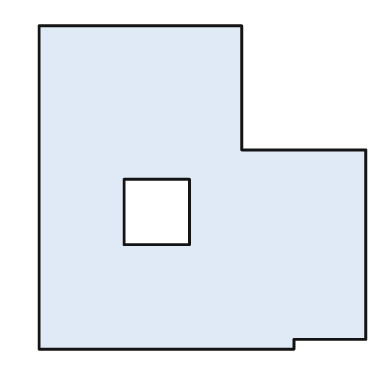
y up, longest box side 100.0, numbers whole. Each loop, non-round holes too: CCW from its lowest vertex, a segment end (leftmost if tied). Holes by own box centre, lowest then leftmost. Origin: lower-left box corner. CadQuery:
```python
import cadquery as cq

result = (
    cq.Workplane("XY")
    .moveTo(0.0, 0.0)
    .lineTo(78.0, 0.0)
    .lineTo(78.0, 3.0)
    .lineTo(100.0, 3.0)
    .lineTo(100.0, 61.0)
    .lineTo(62.0, 61.0)
    .lineTo(62.0, 99.0)
    .lineTo(0.0, 99.0)
    .close()
    .moveTo(26.0, 32.0)
    .lineTo(46.0, 32.0)
    .lineTo(46.0, 52.0)
    .lineTo(26.0, 52.0)
    .close()
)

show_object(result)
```